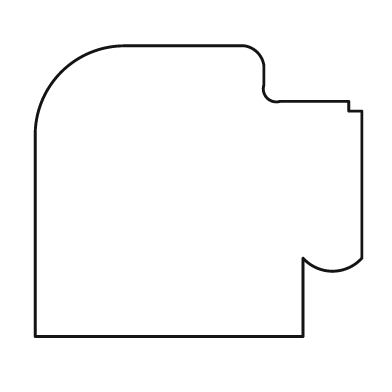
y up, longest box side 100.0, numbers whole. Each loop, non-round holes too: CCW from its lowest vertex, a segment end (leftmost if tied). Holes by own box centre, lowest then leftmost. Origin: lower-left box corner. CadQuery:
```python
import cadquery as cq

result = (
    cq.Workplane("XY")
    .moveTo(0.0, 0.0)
    .lineTo(82.0, 0.0)
    .lineTo(82.0, 24.0)
    .threePointArc((91.0, 20.0), (100.0, 24.0))
    .lineTo(100.0, 69.0)
    .lineTo(96.0, 69.0)
    .lineTo(96.0, 72.0)
    .lineTo(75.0, 72.0)
    .threePointArc((71.0, 73.0), (70.0, 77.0))
    .lineTo(70.0, 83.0)
    .threePointArc((68.0, 87.0), (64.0, 89.0))
    .lineTo(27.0, 89.0)
    .threePointArc((8.0, 81.0), (0.0, 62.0))
    .close()
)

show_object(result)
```